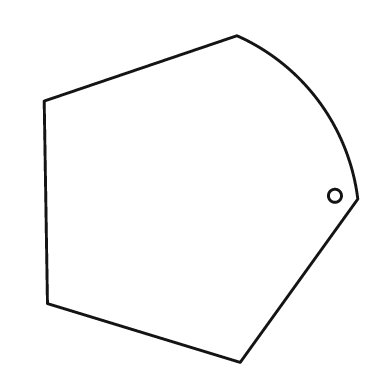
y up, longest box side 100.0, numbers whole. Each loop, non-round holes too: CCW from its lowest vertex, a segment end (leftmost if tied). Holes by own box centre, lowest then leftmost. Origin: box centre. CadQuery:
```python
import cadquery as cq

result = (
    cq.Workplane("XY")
    .moveTo(12.0, -50.0)
    .lineTo(48.0, 0.0)
    .threePointArc((36.0, 30.0), (11.0, 50.0))
    .lineTo(-48.0, 30.0)
    .lineTo(-47.0, -32.0)
    .close()
    .moveTo(41.0, 1.0)
    .circle(2.0)
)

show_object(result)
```